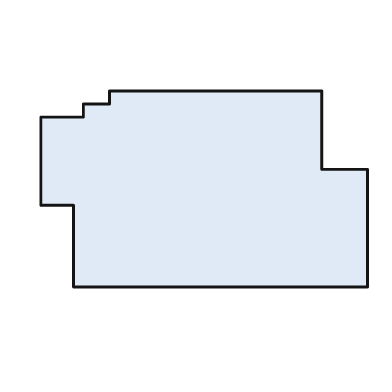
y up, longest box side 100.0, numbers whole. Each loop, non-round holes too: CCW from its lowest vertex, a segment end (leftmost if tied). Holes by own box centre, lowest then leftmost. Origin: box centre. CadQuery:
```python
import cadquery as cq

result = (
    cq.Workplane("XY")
    .moveTo(-40.0, -30.0)
    .lineTo(50.0, -30.0)
    .lineTo(50.0, 6.0)
    .lineTo(36.0, 6.0)
    .lineTo(36.0, 30.0)
    .lineTo(-29.0, 30.0)
    .lineTo(-29.0, 26.0)
    .lineTo(-37.0, 26.0)
    .lineTo(-37.0, 22.0)
    .lineTo(-50.0, 22.0)
    .lineTo(-50.0, -5.0)
    .lineTo(-40.0, -5.0)
    .close()
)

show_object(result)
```